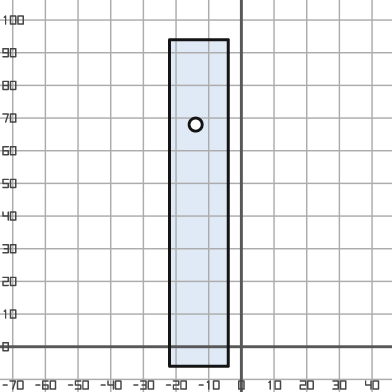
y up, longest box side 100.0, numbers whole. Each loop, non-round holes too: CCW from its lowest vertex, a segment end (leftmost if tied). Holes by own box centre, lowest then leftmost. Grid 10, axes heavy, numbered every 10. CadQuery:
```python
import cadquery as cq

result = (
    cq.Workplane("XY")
    .moveTo(-22.0, -6.0)
    .lineTo(-4.0, -6.0)
    .lineTo(-4.0, 94.0)
    .lineTo(-22.0, 94.0)
    .close()
    .moveTo(-14.0, 68.0)
    .circle(2.0)
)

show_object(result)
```